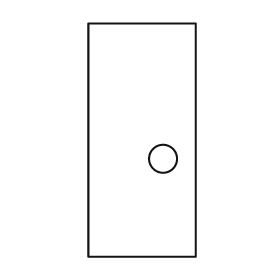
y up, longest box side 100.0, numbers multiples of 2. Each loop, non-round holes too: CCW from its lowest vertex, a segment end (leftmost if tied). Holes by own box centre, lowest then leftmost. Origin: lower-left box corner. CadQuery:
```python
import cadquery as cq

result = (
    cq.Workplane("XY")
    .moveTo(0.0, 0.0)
    .lineTo(46.0, 0.0)
    .lineTo(46.0, 100.0)
    .lineTo(0.0, 100.0)
    .close()
    .moveTo(32.0, 42.0)
    .circle(6.0)
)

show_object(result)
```